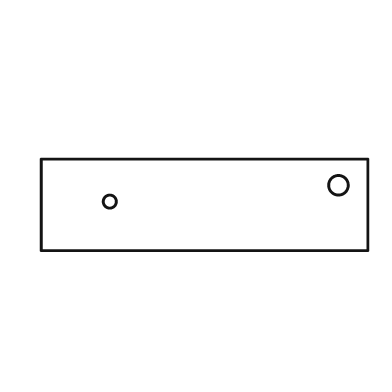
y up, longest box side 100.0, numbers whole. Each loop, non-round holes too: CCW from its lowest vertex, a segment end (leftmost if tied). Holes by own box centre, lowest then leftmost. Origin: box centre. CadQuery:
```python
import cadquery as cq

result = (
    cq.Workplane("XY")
    .moveTo(-50.0, -14.0)
    .lineTo(50.0, -14.0)
    .lineTo(50.0, 14.0)
    .lineTo(-50.0, 14.0)
    .close()
    .moveTo(-29.0, 1.0)
    .circle(2.0)
    .moveTo(41.0, 6.0)
    .circle(3.0)
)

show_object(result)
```